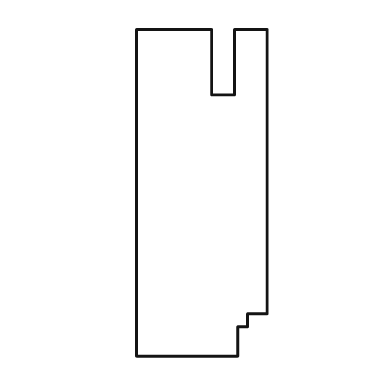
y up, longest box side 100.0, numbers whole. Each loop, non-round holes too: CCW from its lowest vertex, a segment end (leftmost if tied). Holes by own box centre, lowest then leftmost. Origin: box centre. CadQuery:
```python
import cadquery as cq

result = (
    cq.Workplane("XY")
    .moveTo(-20.0, -50.0)
    .lineTo(11.0, -50.0)
    .lineTo(11.0, -41.0)
    .lineTo(14.0, -41.0)
    .lineTo(14.0, -37.0)
    .lineTo(20.0, -37.0)
    .lineTo(20.0, 50.0)
    .lineTo(10.0, 50.0)
    .lineTo(10.0, 30.0)
    .lineTo(3.0, 30.0)
    .lineTo(3.0, 50.0)
    .lineTo(-20.0, 50.0)
    .close()
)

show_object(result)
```